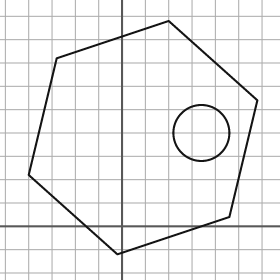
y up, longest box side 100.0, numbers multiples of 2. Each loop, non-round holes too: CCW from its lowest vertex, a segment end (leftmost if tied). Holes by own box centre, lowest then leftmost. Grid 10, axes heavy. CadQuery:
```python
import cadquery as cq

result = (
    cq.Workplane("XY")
    .moveTo(-2.0, -12.0)
    .lineTo(46.0, 4.0)
    .lineTo(58.0, 54.0)
    .lineTo(20.0, 88.0)
    .lineTo(-28.0, 72.0)
    .lineTo(-40.0, 22.0)
    .close()
    .moveTo(34.0, 40.0)
    .circle(12.0)
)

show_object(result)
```